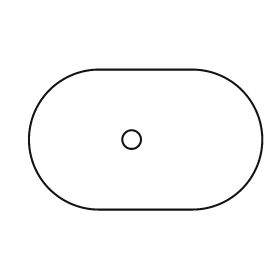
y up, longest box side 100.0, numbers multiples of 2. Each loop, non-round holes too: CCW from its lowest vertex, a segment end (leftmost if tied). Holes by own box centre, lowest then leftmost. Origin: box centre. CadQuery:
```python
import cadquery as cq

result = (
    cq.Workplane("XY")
    .moveTo(-20.0, -30.0)
    .lineTo(20.0, -30.0)
    .threePointArc((50.0, 0.0), (20.0, 30.0))
    .lineTo(-20.0, 30.0)
    .threePointArc((-50.0, 0.0), (-20.0, -30.0))
    .close()
    .moveTo(-6.0, 0.0)
    .circle(4.0)
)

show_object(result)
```